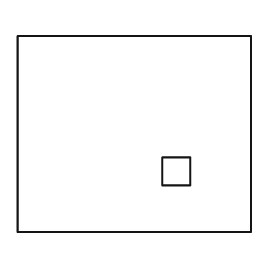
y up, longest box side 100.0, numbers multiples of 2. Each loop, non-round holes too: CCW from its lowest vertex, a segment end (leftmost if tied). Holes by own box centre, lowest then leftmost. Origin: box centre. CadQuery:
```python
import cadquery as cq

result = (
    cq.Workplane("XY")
    .moveTo(-50.0, -42.0)
    .lineTo(50.0, -42.0)
    .lineTo(50.0, 42.0)
    .lineTo(-50.0, 42.0)
    .close()
    .moveTo(12.0, -22.0)
    .lineTo(24.0, -22.0)
    .lineTo(24.0, -10.0)
    .lineTo(12.0, -10.0)
    .close()
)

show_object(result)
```